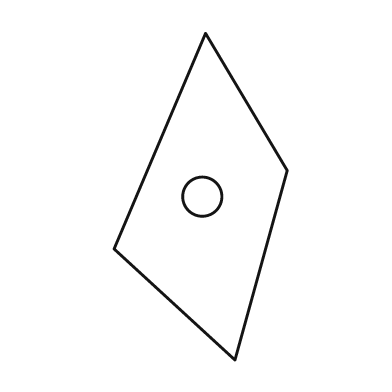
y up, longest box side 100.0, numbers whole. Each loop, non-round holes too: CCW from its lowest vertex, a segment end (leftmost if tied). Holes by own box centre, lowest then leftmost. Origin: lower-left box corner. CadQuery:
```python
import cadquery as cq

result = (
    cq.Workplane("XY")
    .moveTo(37.0, 0.0)
    .lineTo(53.0, 58.0)
    .lineTo(28.0, 100.0)
    .lineTo(0.0, 34.0)
    .close()
    .moveTo(27.0, 50.0)
    .circle(6.0)
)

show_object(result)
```